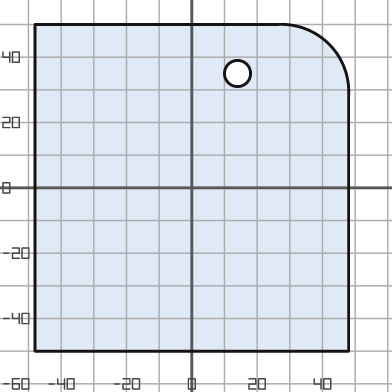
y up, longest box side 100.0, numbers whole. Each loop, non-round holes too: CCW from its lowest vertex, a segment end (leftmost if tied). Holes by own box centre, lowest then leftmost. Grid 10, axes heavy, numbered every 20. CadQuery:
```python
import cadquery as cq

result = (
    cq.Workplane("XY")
    .moveTo(-48.0, -50.0)
    .lineTo(48.0, -50.0)
    .lineTo(48.0, 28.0)
    .threePointArc((42.0, 44.0), (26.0, 50.0))
    .lineTo(-48.0, 50.0)
    .close()
    .moveTo(14.0, 35.0)
    .circle(4.0)
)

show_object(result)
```